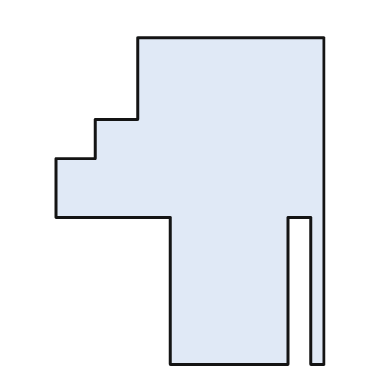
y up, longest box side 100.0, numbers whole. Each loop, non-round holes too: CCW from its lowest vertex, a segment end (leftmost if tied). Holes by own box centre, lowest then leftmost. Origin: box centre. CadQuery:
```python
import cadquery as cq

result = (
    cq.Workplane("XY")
    .moveTo(-6.0, -50.0)
    .lineTo(30.0, -50.0)
    .lineTo(30.0, -5.0)
    .lineTo(37.0, -5.0)
    .lineTo(37.0, -50.0)
    .lineTo(41.0, -50.0)
    .lineTo(41.0, 50.0)
    .lineTo(-16.0, 50.0)
    .lineTo(-16.0, 25.0)
    .lineTo(-29.0, 25.0)
    .lineTo(-29.0, 13.0)
    .lineTo(-41.0, 13.0)
    .lineTo(-41.0, -5.0)
    .lineTo(-6.0, -5.0)
    .close()
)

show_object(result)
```